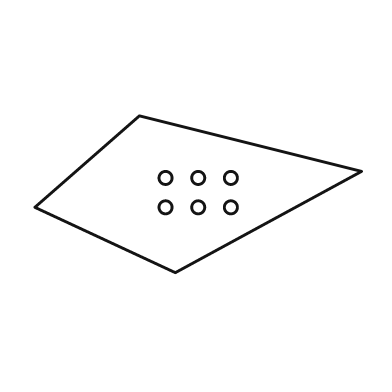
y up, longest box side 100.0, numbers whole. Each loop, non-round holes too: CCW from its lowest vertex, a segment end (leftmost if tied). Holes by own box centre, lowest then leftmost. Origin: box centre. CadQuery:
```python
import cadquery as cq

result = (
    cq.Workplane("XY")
    .moveTo(-7.0, -24.0)
    .lineTo(50.0, 7.0)
    .lineTo(-18.0, 24.0)
    .lineTo(-50.0, -4.0)
    .close()
    .moveTo(-10.0, -4.0)
    .circle(2.0)
    .moveTo(0.0, -4.0)
    .circle(2.0)
    .moveTo(10.0, -4.0)
    .circle(2.0)
    .moveTo(-10.0, 5.0)
    .circle(2.0)
    .moveTo(0.0, 5.0)
    .circle(2.0)
    .moveTo(10.0, 5.0)
    .circle(2.0)
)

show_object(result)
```